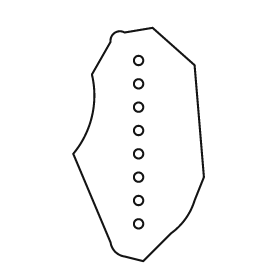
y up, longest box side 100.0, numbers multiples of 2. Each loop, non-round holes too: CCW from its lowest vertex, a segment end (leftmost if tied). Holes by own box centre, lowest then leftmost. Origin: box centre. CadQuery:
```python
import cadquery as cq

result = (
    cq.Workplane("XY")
    .moveTo(2.0, -50.0)
    .lineTo(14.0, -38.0)
    .threePointArc((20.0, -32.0), (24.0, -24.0))
    .lineTo(28.0, -14.0)
    .lineTo(24.0, 34.0)
    .lineTo(6.0, 50.0)
    .lineTo(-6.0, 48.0)
    .threePointArc((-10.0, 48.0), (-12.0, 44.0))
    .lineTo(-20.0, 30.0)
    .threePointArc((-20.0, 12.0), (-28.0, -4.0))
    .lineTo(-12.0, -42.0)
    .threePointArc((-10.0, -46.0), (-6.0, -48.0))
    .close()
    .moveTo(0.0, -34.0)
    .circle(2.0)
    .moveTo(0.0, -24.0)
    .circle(2.0)
    .moveTo(0.0, -14.0)
    .circle(2.0)
    .moveTo(0.0, -4.0)
    .circle(2.0)
    .moveTo(0.0, 6.0)
    .circle(2.0)
    .moveTo(0.0, 16.0)
    .circle(2.0)
    .moveTo(0.0, 26.0)
    .circle(2.0)
    .moveTo(0.0, 36.0)
    .circle(2.0)
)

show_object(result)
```